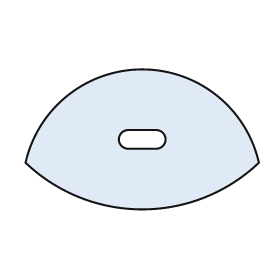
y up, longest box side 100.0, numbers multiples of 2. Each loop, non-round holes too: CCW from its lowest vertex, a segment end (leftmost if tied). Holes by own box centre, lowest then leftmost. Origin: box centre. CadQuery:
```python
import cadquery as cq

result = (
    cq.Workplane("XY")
    .moveTo(-50.0, -10.0)
    .threePointArc((0.0, -30.0), (50.0, -10.0))
    .threePointArc((0.0, 30.0), (-50.0, -10.0))
    .close()
    .moveTo(-6.0, -4.0)
    .lineTo(6.0, -4.0)
    .threePointArc((10.0, 0.0), (6.0, 4.0))
    .lineTo(-6.0, 4.0)
    .threePointArc((-10.0, 0.0), (-6.0, -4.0))
    .close()
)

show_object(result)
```